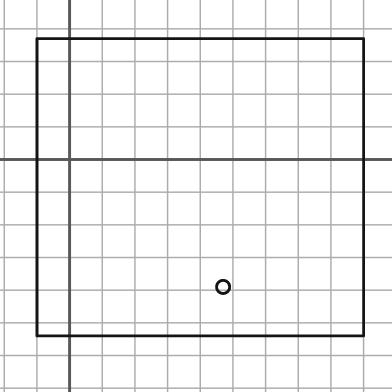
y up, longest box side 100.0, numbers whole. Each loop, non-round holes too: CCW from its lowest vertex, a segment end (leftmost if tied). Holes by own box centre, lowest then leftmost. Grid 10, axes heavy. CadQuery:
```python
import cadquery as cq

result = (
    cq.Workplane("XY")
    .moveTo(-10.0, -54.0)
    .lineTo(90.0, -54.0)
    .lineTo(90.0, 37.0)
    .lineTo(-10.0, 37.0)
    .close()
    .moveTo(47.0, -39.0)
    .circle(2.0)
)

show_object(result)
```